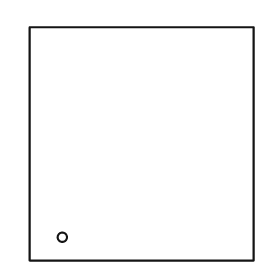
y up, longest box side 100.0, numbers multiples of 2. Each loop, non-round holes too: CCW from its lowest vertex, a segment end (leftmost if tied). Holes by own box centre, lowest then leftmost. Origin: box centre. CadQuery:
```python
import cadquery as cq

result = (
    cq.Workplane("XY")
    .moveTo(-48.0, -50.0)
    .lineTo(48.0, -50.0)
    .lineTo(48.0, 50.0)
    .lineTo(-48.0, 50.0)
    .close()
    .moveTo(-34.0, -40.0)
    .circle(2.0)
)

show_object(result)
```